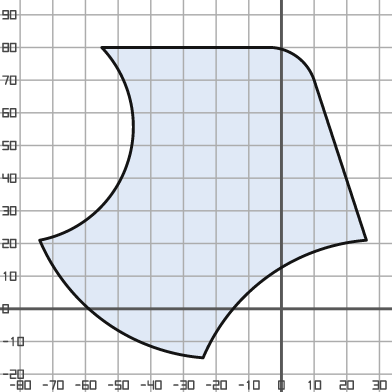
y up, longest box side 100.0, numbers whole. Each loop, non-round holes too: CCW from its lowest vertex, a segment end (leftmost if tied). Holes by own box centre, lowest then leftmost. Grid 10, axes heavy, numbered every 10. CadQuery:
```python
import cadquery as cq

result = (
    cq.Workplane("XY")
    .moveTo(-24.0, -15.0)
    .threePointArc((-4.0, 10.0), (26.0, 21.0))
    .lineTo(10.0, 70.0)
    .threePointArc((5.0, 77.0), (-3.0, 80.0))
    .lineTo(-55.0, 80.0)
    .threePointArc((-47.0, 45.0), (-74.0, 21.0))
    .threePointArc((-54.0, -4.0), (-24.0, -15.0))
    .close()
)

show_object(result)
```